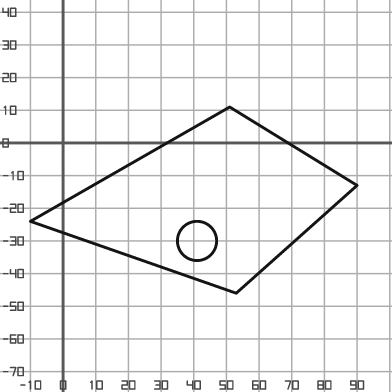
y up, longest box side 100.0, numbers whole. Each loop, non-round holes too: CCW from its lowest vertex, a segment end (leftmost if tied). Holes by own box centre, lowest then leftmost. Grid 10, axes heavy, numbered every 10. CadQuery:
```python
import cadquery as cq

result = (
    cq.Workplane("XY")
    .moveTo(53.0, -46.0)
    .lineTo(90.0, -13.0)
    .lineTo(51.0, 11.0)
    .lineTo(-10.0, -24.0)
    .close()
    .moveTo(41.0, -30.0)
    .circle(6.0)
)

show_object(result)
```